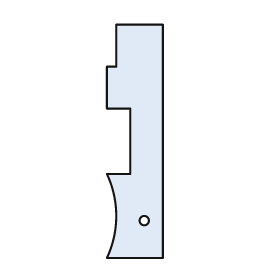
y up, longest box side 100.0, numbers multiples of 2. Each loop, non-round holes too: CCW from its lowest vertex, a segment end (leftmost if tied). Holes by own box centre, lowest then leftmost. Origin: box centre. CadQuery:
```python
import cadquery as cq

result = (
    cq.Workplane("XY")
    .moveTo(-12.0, -50.0)
    .lineTo(12.0, -50.0)
    .lineTo(12.0, 50.0)
    .lineTo(-8.0, 50.0)
    .lineTo(-8.0, 32.0)
    .lineTo(-12.0, 32.0)
    .lineTo(-12.0, 14.0)
    .lineTo(-2.0, 14.0)
    .lineTo(-2.0, -14.0)
    .lineTo(-12.0, -14.0)
    .threePointArc((-8.0, -32.0), (-12.0, -50.0))
    .close()
    .moveTo(4.0, -34.0)
    .circle(2.0)
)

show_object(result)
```